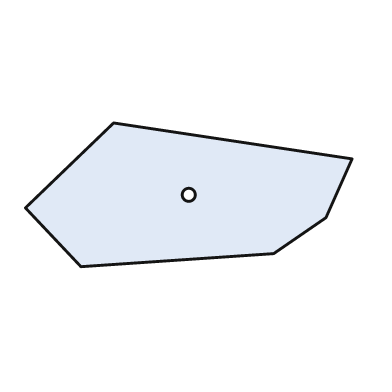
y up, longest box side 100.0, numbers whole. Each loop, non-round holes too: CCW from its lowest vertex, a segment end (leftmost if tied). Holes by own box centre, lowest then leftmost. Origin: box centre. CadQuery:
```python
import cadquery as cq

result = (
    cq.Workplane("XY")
    .moveTo(-33.0, -22.0)
    .lineTo(26.0, -18.0)
    .lineTo(42.0, -7.0)
    .lineTo(50.0, 11.0)
    .lineTo(-23.0, 22.0)
    .lineTo(-50.0, -4.0)
    .close()
    .moveTo(0.0, 0.0)
    .circle(2.0)
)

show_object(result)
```